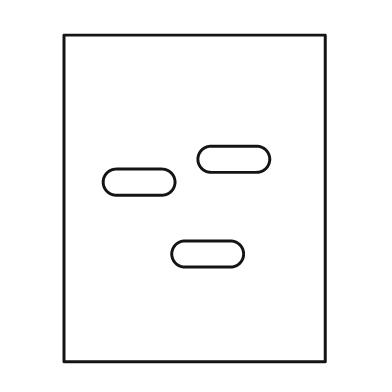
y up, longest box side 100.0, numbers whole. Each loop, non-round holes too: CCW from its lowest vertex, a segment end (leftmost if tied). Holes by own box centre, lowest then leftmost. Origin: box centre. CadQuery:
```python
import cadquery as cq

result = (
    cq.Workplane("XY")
    .moveTo(-40.0, -50.0)
    .lineTo(40.0, -50.0)
    .lineTo(40.0, 50.0)
    .lineTo(-40.0, 50.0)
    .close()
    .moveTo(-3.0, -21.0)
    .lineTo(11.0, -21.0)
    .threePointArc((15.0, -17.0), (11.0, -13.0))
    .lineTo(-3.0, -13.0)
    .threePointArc((-7.0, -17.0), (-3.0, -21.0))
    .close()
    .moveTo(-24.0, 1.0)
    .lineTo(-10.0, 1.0)
    .threePointArc((-6.0, 5.0), (-10.0, 9.0))
    .lineTo(-24.0, 9.0)
    .threePointArc((-28.0, 5.0), (-24.0, 1.0))
    .close()
    .moveTo(5.0, 8.0)
    .lineTo(19.0, 8.0)
    .threePointArc((23.0, 12.0), (19.0, 16.0))
    .lineTo(5.0, 16.0)
    .threePointArc((1.0, 12.0), (5.0, 8.0))
    .close()
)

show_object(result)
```